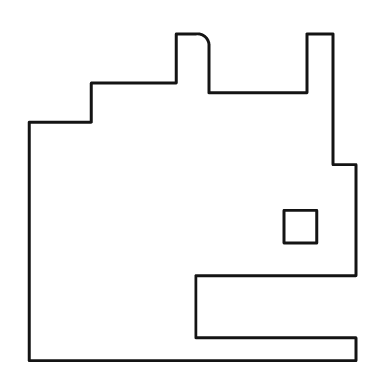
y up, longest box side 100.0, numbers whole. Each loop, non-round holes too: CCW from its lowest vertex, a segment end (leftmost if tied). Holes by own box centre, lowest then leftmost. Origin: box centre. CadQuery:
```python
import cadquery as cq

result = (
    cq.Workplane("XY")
    .moveTo(-50.0, -50.0)
    .lineTo(50.0, -50.0)
    .lineTo(50.0, -43.0)
    .lineTo(1.0, -43.0)
    .lineTo(1.0, -24.0)
    .lineTo(50.0, -24.0)
    .lineTo(50.0, 10.0)
    .lineTo(43.0, 10.0)
    .lineTo(43.0, 50.0)
    .lineTo(35.0, 50.0)
    .lineTo(35.0, 32.0)
    .lineTo(5.0, 32.0)
    .lineTo(5.0, 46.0)
    .threePointArc((4.0, 49.0), (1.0, 50.0))
    .lineTo(-5.0, 50.0)
    .lineTo(-5.0, 35.0)
    .lineTo(-31.0, 35.0)
    .lineTo(-31.0, 23.0)
    .lineTo(-50.0, 23.0)
    .close()
    .moveTo(28.0, -14.0)
    .lineTo(38.0, -14.0)
    .lineTo(38.0, -4.0)
    .lineTo(28.0, -4.0)
    .close()
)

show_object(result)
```